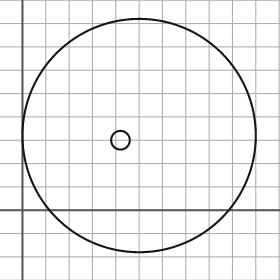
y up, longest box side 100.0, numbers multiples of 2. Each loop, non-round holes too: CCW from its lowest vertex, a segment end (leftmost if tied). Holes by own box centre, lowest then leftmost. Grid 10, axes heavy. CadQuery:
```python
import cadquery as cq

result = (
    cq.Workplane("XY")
    .moveTo(50.0, 32.0)
    .circle(50.0)
    .moveTo(42.0, 30.0)
    .circle(4.0)
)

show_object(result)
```